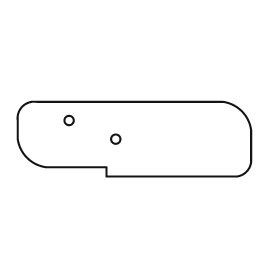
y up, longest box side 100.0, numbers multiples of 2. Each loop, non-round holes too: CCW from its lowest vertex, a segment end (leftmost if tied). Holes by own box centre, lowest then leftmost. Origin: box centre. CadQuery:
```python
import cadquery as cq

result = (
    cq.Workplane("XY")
    .moveTo(-12.0, -16.0)
    .lineTo(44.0, -16.0)
    .threePointArc((48.0, -14.0), (50.0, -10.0))
    .lineTo(50.0, 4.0)
    .threePointArc((46.0, 12.0), (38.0, 16.0))
    .lineTo(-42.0, 16.0)
    .threePointArc((-48.0, 14.0), (-50.0, 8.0))
    .lineTo(-50.0, 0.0)
    .threePointArc((-46.0, -8.0), (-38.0, -12.0))
    .lineTo(-12.0, -12.0)
    .close()
    .moveTo(-8.0, 0.0)
    .circle(2.0)
    .moveTo(-28.0, 8.0)
    .circle(2.0)
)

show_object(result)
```